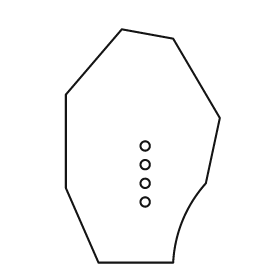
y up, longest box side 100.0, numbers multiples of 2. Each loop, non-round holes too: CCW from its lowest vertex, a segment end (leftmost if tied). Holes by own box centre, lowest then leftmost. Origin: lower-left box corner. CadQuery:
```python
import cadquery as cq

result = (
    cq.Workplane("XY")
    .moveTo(14.0, 0.0)
    .lineTo(46.0, 0.0)
    .threePointArc((50.0, 18.0), (60.0, 34.0))
    .lineTo(66.0, 62.0)
    .lineTo(46.0, 96.0)
    .lineTo(24.0, 100.0)
    .lineTo(0.0, 72.0)
    .lineTo(0.0, 32.0)
    .close()
    .moveTo(34.0, 26.0)
    .circle(2.0)
    .moveTo(34.0, 34.0)
    .circle(2.0)
    .moveTo(34.0, 42.0)
    .circle(2.0)
    .moveTo(34.0, 50.0)
    .circle(2.0)
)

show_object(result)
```